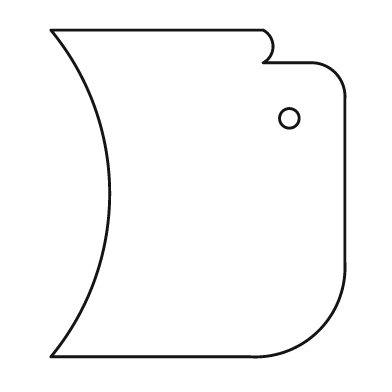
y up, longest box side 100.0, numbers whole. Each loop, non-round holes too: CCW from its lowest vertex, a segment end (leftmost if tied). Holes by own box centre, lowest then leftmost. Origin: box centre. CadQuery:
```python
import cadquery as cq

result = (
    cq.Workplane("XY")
    .moveTo(-45.0, -50.0)
    .lineTo(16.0, -50.0)
    .threePointArc((37.0, -42.0), (45.0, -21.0))
    .lineTo(45.0, 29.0)
    .threePointArc((42.0, 37.0), (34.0, 40.0))
    .lineTo(20.0, 40.0)
    .threePointArc((23.0, 45.0), (20.0, 50.0))
    .lineTo(-45.0, 50.0)
    .threePointArc((-27.0, 0.0), (-45.0, -50.0))
    .close()
    .moveTo(28.0, 23.0)
    .circle(3.0)
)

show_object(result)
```